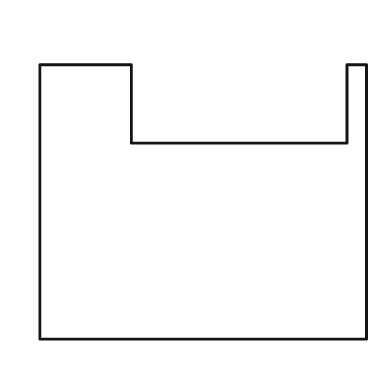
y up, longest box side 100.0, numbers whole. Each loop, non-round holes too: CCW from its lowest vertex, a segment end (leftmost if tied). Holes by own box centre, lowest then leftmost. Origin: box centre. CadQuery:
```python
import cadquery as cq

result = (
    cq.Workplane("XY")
    .moveTo(-50.0, -42.0)
    .lineTo(50.0, -42.0)
    .lineTo(50.0, 42.0)
    .lineTo(44.0, 42.0)
    .lineTo(44.0, 18.0)
    .lineTo(-22.0, 18.0)
    .lineTo(-22.0, 42.0)
    .lineTo(-50.0, 42.0)
    .close()
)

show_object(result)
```